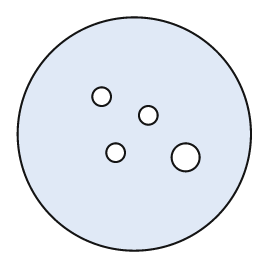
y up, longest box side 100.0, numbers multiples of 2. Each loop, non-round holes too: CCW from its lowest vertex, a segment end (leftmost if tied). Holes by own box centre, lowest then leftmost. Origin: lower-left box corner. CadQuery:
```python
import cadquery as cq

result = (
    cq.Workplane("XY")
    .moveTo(50.0, 50.0)
    .circle(50.0)
    .moveTo(72.0, 40.0)
    .circle(6.0)
    .moveTo(42.0, 42.0)
    .circle(4.0)
    .moveTo(56.0, 58.0)
    .circle(4.0)
    .moveTo(36.0, 66.0)
    .circle(4.0)
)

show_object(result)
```